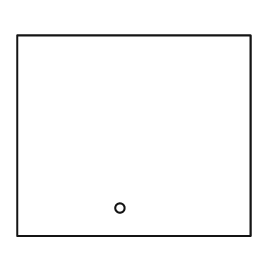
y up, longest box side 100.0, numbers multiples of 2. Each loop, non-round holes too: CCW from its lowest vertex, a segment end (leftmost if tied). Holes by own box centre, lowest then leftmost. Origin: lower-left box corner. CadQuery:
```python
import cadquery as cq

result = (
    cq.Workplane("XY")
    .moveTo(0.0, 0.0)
    .lineTo(100.0, 0.0)
    .lineTo(100.0, 86.0)
    .lineTo(0.0, 86.0)
    .close()
    .moveTo(44.0, 12.0)
    .circle(2.0)
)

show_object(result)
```